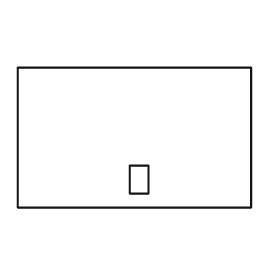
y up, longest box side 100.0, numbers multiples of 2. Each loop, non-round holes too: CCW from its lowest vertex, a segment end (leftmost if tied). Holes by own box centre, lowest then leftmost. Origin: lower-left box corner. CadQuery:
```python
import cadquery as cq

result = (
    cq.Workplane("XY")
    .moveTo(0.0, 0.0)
    .lineTo(100.0, 0.0)
    .lineTo(100.0, 60.0)
    .lineTo(0.0, 60.0)
    .close()
    .moveTo(48.0, 6.0)
    .lineTo(56.0, 6.0)
    .lineTo(56.0, 18.0)
    .lineTo(48.0, 18.0)
    .close()
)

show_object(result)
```